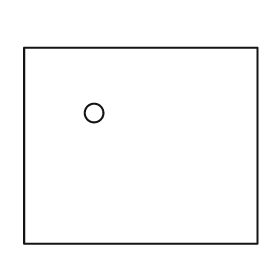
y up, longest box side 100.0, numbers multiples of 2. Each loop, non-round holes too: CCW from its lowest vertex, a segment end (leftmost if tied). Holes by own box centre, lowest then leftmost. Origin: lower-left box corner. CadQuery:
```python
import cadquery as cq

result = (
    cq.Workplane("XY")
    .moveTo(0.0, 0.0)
    .lineTo(100.0, 0.0)
    .lineTo(100.0, 84.0)
    .lineTo(0.0, 84.0)
    .close()
    .moveTo(30.0, 56.0)
    .circle(4.0)
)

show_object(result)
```